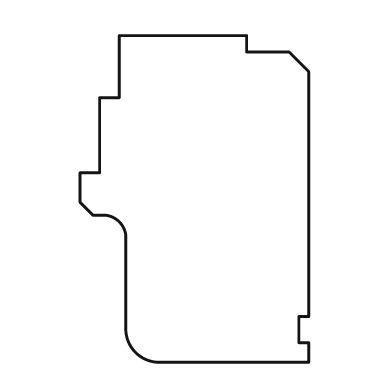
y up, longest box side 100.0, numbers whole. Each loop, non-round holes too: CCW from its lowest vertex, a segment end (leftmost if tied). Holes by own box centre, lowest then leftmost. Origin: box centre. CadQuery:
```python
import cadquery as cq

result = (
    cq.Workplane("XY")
    .moveTo(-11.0, -50.0)
    .lineTo(35.0, -50.0)
    .lineTo(35.0, -44.0)
    .lineTo(32.0, -44.0)
    .lineTo(32.0, -36.0)
    .lineTo(35.0, -36.0)
    .lineTo(35.0, 39.0)
    .lineTo(29.0, 45.0)
    .lineTo(16.0, 45.0)
    .lineTo(16.0, 50.0)
    .lineTo(-23.0, 50.0)
    .lineTo(-23.0, 31.0)
    .lineTo(-29.0, 31.0)
    .lineTo(-29.0, 8.0)
    .lineTo(-35.0, 8.0)
    .lineTo(-35.0, -1.0)
    .lineTo(-31.0, -5.0)
    .lineTo(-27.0, -5.0)
    .threePointArc((-23.0, -7.0), (-21.0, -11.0))
    .lineTo(-21.0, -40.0)
    .threePointArc((-18.0, -47.0), (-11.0, -50.0))
    .close()
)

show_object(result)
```